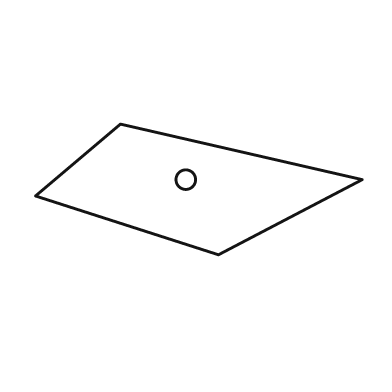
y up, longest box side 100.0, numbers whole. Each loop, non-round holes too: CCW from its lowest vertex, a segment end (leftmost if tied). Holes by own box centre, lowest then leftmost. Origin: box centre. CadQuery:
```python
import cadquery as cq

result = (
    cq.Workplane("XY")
    .moveTo(6.0, -20.0)
    .lineTo(50.0, 3.0)
    .lineTo(-24.0, 20.0)
    .lineTo(-50.0, -2.0)
    .close()
    .moveTo(-4.0, 3.0)
    .circle(3.0)
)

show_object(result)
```